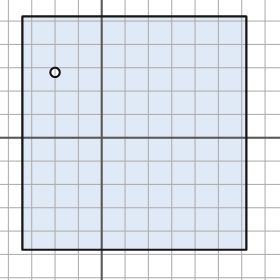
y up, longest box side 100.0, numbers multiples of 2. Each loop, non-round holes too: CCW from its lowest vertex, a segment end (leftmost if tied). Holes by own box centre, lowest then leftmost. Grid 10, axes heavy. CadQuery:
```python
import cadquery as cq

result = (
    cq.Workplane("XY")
    .moveTo(-34.0, -48.0)
    .lineTo(62.0, -48.0)
    .lineTo(62.0, 52.0)
    .lineTo(-34.0, 52.0)
    .close()
    .moveTo(-20.0, 28.0)
    .circle(2.0)
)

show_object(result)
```